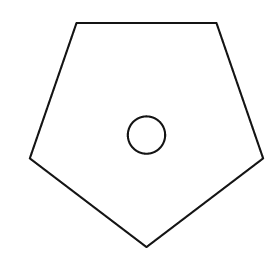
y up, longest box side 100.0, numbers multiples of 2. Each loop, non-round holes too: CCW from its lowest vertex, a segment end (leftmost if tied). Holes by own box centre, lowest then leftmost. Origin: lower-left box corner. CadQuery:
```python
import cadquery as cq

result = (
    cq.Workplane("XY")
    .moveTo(50.0, 0.0)
    .lineTo(100.0, 38.0)
    .lineTo(80.0, 96.0)
    .lineTo(20.0, 96.0)
    .lineTo(0.0, 38.0)
    .close()
    .moveTo(50.0, 48.0)
    .circle(8.0)
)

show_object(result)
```